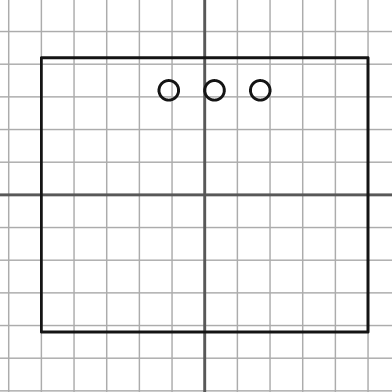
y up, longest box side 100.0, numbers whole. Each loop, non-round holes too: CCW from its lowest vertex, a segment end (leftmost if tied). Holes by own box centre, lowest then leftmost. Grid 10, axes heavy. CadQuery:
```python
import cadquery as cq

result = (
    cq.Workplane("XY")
    .moveTo(-50.0, -42.0)
    .lineTo(50.0, -42.0)
    .lineTo(50.0, 42.0)
    .lineTo(-50.0, 42.0)
    .close()
    .moveTo(-11.0, 32.0)
    .circle(3.0)
    .moveTo(3.0, 32.0)
    .circle(3.0)
    .moveTo(17.0, 32.0)
    .circle(3.0)
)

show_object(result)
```